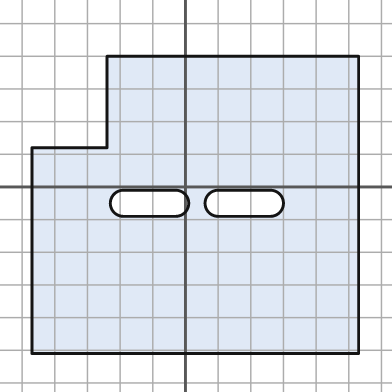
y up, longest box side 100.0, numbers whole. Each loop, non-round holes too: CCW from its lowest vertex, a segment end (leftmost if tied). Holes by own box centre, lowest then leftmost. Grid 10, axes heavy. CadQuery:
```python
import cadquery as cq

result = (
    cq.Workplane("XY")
    .moveTo(-47.0, -51.0)
    .lineTo(53.0, -51.0)
    .lineTo(53.0, 40.0)
    .lineTo(-24.0, 40.0)
    .lineTo(-24.0, 12.0)
    .lineTo(-47.0, 12.0)
    .close()
    .moveTo(-19.0, -9.0)
    .lineTo(-3.0, -9.0)
    .threePointArc((1.0, -5.0), (-3.0, -1.0))
    .lineTo(-19.0, -1.0)
    .threePointArc((-23.0, -5.0), (-19.0, -9.0))
    .close()
    .moveTo(10.0, -9.0)
    .lineTo(26.0, -9.0)
    .threePointArc((30.0, -5.0), (26.0, -1.0))
    .lineTo(10.0, -1.0)
    .threePointArc((6.0, -5.0), (10.0, -9.0))
    .close()
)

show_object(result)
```